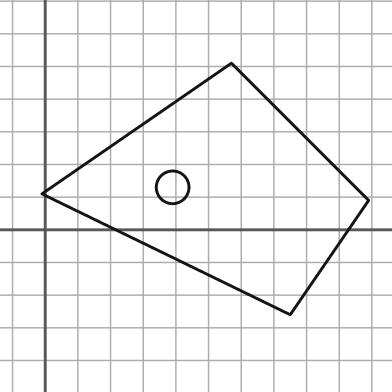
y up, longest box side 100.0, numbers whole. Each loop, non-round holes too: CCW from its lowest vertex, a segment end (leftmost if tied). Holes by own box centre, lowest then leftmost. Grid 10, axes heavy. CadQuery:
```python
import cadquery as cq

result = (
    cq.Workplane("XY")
    .moveTo(75.0, -26.0)
    .lineTo(99.0, 9.0)
    .lineTo(57.0, 51.0)
    .lineTo(-1.0, 11.0)
    .close()
    .moveTo(39.0, 13.0)
    .circle(5.0)
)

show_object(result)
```